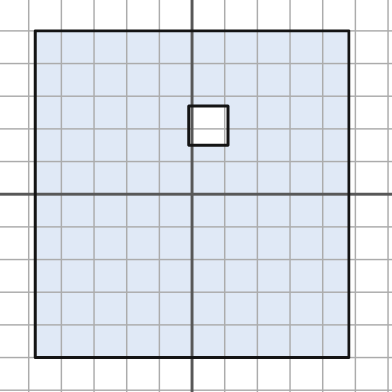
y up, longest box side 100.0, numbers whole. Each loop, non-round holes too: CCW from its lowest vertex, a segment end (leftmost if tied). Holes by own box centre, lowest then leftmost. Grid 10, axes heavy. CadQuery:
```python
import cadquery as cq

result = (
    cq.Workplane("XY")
    .moveTo(-48.0, -50.0)
    .lineTo(48.0, -50.0)
    .lineTo(48.0, 50.0)
    .lineTo(-48.0, 50.0)
    .close()
    .moveTo(-1.0, 15.0)
    .lineTo(11.0, 15.0)
    .lineTo(11.0, 27.0)
    .lineTo(-1.0, 27.0)
    .close()
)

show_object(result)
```